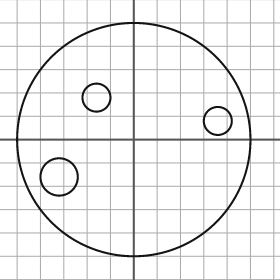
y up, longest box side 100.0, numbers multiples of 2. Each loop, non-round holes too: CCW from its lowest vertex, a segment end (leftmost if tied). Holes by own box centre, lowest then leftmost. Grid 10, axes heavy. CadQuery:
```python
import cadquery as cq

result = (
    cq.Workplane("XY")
    .moveTo(0.0, 0.0)
    .circle(50.0)
    .moveTo(-32.0, -16.0)
    .circle(8.0)
    .moveTo(36.0, 8.0)
    .circle(6.0)
    .moveTo(-16.0, 18.0)
    .circle(6.0)
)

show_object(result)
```